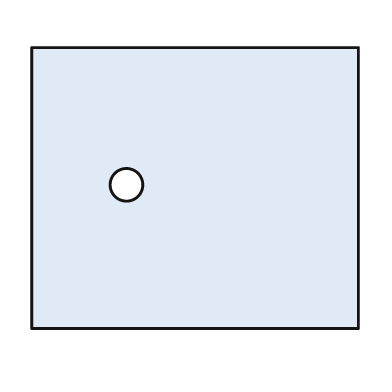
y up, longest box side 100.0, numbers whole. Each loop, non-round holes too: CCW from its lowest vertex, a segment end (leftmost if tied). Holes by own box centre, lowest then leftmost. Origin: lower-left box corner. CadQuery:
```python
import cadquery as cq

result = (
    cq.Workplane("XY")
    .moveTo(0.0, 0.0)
    .lineTo(100.0, 0.0)
    .lineTo(100.0, 86.0)
    .lineTo(0.0, 86.0)
    .close()
    .moveTo(29.0, 44.0)
    .circle(5.0)
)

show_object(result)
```